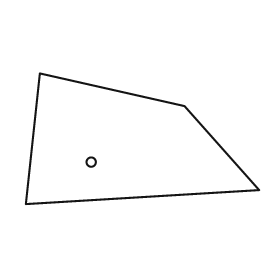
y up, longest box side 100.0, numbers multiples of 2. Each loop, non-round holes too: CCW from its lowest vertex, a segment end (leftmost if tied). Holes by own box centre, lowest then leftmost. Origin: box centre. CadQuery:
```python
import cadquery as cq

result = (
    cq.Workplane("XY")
    .moveTo(-50.0, -28.0)
    .lineTo(50.0, -22.0)
    .lineTo(18.0, 14.0)
    .lineTo(-44.0, 28.0)
    .close()
    .moveTo(-22.0, -10.0)
    .circle(2.0)
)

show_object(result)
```